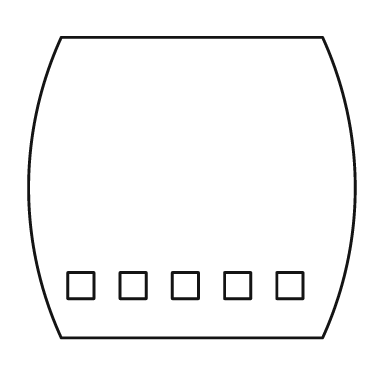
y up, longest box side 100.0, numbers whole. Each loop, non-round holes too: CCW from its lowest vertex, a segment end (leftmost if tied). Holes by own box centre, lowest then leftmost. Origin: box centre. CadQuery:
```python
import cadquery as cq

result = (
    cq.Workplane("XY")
    .moveTo(-40.0, -46.0)
    .lineTo(40.0, -46.0)
    .threePointArc((50.0, 0.0), (40.0, 46.0))
    .lineTo(-40.0, 46.0)
    .threePointArc((-50.0, 0.0), (-40.0, -46.0))
    .close()
    .moveTo(-38.0, -34.0)
    .lineTo(-30.0, -34.0)
    .lineTo(-30.0, -26.0)
    .lineTo(-38.0, -26.0)
    .close()
    .moveTo(-22.0, -34.0)
    .lineTo(-14.0, -34.0)
    .lineTo(-14.0, -26.0)
    .lineTo(-22.0, -26.0)
    .close()
    .moveTo(-6.0, -34.0)
    .lineTo(2.0, -34.0)
    .lineTo(2.0, -26.0)
    .lineTo(-6.0, -26.0)
    .close()
    .moveTo(10.0, -34.0)
    .lineTo(18.0, -34.0)
    .lineTo(18.0, -26.0)
    .lineTo(10.0, -26.0)
    .close()
    .moveTo(26.0, -34.0)
    .lineTo(34.0, -34.0)
    .lineTo(34.0, -26.0)
    .lineTo(26.0, -26.0)
    .close()
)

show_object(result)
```